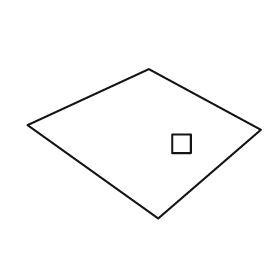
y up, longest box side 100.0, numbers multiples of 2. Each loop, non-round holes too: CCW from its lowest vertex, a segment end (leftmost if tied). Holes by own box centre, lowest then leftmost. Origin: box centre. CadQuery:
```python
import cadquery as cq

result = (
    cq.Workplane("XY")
    .moveTo(6.0, -32.0)
    .lineTo(50.0, 6.0)
    .lineTo(2.0, 32.0)
    .lineTo(-50.0, 8.0)
    .close()
    .moveTo(12.0, -4.0)
    .lineTo(20.0, -4.0)
    .lineTo(20.0, 4.0)
    .lineTo(12.0, 4.0)
    .close()
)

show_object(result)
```